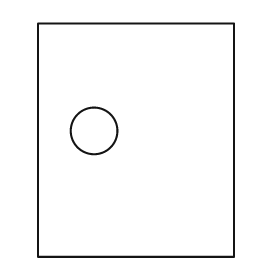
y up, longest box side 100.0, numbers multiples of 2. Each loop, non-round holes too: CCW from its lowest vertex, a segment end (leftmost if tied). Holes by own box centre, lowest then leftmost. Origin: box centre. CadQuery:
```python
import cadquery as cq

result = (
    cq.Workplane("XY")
    .moveTo(-42.0, -50.0)
    .lineTo(42.0, -50.0)
    .lineTo(42.0, 50.0)
    .lineTo(-42.0, 50.0)
    .close()
    .moveTo(-18.0, 4.0)
    .circle(10.0)
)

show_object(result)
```